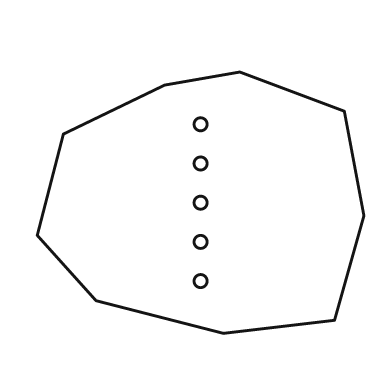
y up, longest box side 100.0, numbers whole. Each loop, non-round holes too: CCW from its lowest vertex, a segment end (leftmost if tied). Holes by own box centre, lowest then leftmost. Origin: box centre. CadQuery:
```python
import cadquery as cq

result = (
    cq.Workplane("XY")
    .moveTo(7.0, -40.0)
    .lineTo(41.0, -36.0)
    .lineTo(50.0, -4.0)
    .lineTo(44.0, 28.0)
    .lineTo(12.0, 40.0)
    .lineTo(-11.0, 36.0)
    .lineTo(-42.0, 21.0)
    .lineTo(-50.0, -10.0)
    .lineTo(-32.0, -30.0)
    .close()
    .moveTo(0.0, -24.0)
    .circle(2.0)
    .moveTo(0.0, -12.0)
    .circle(2.0)
    .moveTo(0.0, 0.0)
    .circle(2.0)
    .moveTo(0.0, 12.0)
    .circle(2.0)
    .moveTo(0.0, 24.0)
    .circle(2.0)
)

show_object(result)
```